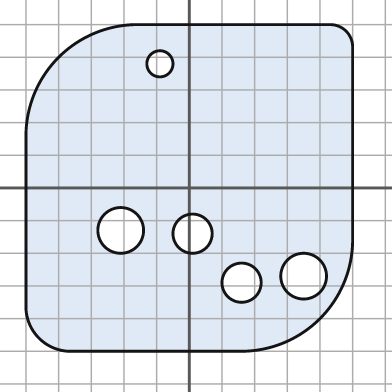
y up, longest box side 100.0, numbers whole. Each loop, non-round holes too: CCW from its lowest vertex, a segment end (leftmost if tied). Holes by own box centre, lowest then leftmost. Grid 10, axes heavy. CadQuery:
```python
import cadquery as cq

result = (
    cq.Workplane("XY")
    .moveTo(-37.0, -50.0)
    .lineTo(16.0, -50.0)
    .threePointArc((40.0, -40.0), (50.0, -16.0))
    .lineTo(50.0, 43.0)
    .threePointArc((48.0, 48.0), (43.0, 50.0))
    .lineTo(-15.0, 50.0)
    .threePointArc((-40.0, 40.0), (-50.0, 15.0))
    .lineTo(-50.0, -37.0)
    .threePointArc((-46.0, -46.0), (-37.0, -50.0))
    .close()
    .moveTo(16.0, -29.0)
    .circle(6.0)
    .moveTo(35.0, -27.0)
    .circle(7.0)
    .moveTo(1.0, -14.0)
    .circle(6.0)
    .moveTo(-21.0, -13.0)
    .circle(7.0)
    .moveTo(-9.0, 38.0)
    .circle(4.0)
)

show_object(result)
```